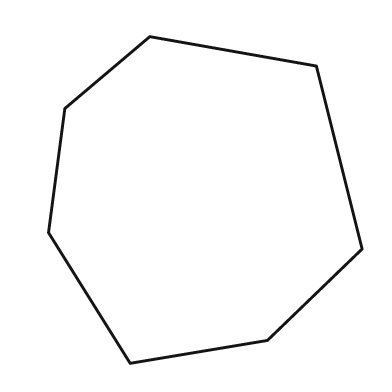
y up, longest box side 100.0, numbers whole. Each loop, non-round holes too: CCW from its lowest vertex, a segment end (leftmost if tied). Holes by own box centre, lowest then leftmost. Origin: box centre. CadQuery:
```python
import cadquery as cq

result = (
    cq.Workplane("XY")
    .moveTo(-23.0, -50.0)
    .lineTo(19.0, -43.0)
    .lineTo(48.0, -15.0)
    .lineTo(34.0, 41.0)
    .lineTo(-17.0, 50.0)
    .lineTo(-43.0, 28.0)
    .lineTo(-48.0, -10.0)
    .close()
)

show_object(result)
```